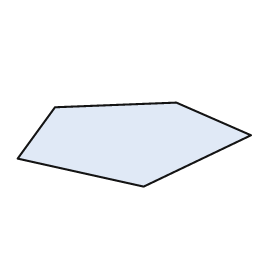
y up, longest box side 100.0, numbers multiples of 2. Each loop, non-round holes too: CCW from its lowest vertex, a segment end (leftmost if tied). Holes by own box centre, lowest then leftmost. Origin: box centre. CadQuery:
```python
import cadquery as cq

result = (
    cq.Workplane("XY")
    .moveTo(4.0, -18.0)
    .lineTo(50.0, 4.0)
    .lineTo(18.0, 18.0)
    .lineTo(-34.0, 16.0)
    .lineTo(-50.0, -6.0)
    .close()
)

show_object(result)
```